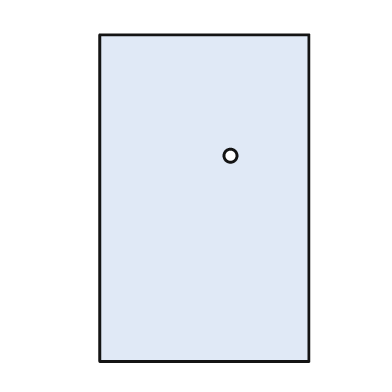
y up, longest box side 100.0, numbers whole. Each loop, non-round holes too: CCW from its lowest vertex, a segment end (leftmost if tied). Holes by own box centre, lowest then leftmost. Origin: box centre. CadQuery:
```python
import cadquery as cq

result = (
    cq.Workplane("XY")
    .moveTo(-32.0, -50.0)
    .lineTo(32.0, -50.0)
    .lineTo(32.0, 50.0)
    .lineTo(-32.0, 50.0)
    .close()
    .moveTo(8.0, 13.0)
    .circle(2.0)
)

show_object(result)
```